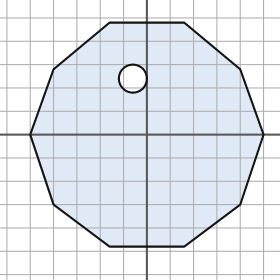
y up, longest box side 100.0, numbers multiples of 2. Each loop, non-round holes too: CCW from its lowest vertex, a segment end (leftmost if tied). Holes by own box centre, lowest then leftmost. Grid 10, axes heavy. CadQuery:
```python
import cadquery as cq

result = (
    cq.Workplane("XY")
    .moveTo(-16.0, -48.0)
    .lineTo(16.0, -48.0)
    .lineTo(40.0, -30.0)
    .lineTo(50.0, 0.0)
    .lineTo(40.0, 28.0)
    .lineTo(16.0, 48.0)
    .lineTo(-16.0, 48.0)
    .lineTo(-40.0, 28.0)
    .lineTo(-50.0, 0.0)
    .lineTo(-40.0, -30.0)
    .close()
    .moveTo(-6.0, 24.0)
    .circle(6.0)
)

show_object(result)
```